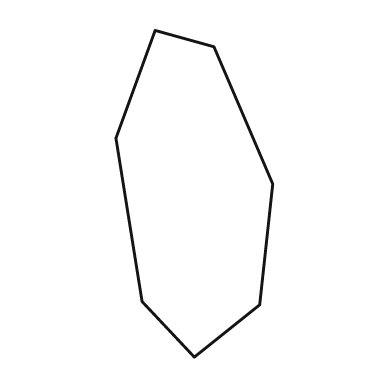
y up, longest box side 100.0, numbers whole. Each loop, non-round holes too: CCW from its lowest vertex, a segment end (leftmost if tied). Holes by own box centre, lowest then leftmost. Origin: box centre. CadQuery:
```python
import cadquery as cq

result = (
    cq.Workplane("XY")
    .moveTo(0.0, -50.0)
    .lineTo(20.0, -34.0)
    .lineTo(24.0, 3.0)
    .lineTo(6.0, 45.0)
    .lineTo(-12.0, 50.0)
    .lineTo(-24.0, 17.0)
    .lineTo(-16.0, -33.0)
    .close()
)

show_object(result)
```